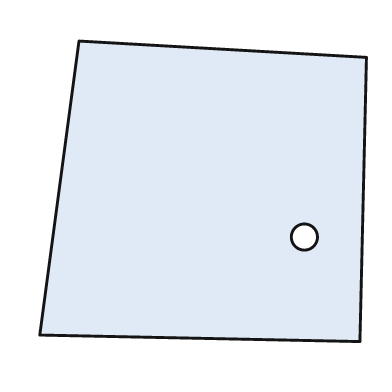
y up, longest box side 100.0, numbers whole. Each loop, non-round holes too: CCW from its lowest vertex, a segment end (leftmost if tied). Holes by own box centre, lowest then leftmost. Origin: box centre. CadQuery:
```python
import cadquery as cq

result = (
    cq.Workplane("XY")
    .moveTo(48.0, -46.0)
    .lineTo(50.0, 41.0)
    .lineTo(-38.0, 46.0)
    .lineTo(-50.0, -44.0)
    .close()
    .moveTo(31.0, -14.0)
    .circle(4.0)
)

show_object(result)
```